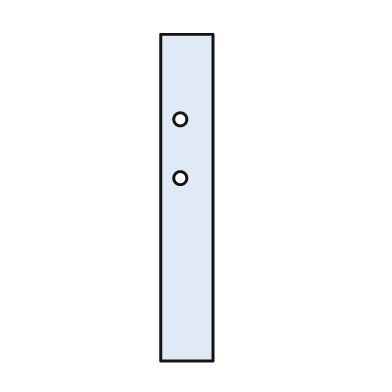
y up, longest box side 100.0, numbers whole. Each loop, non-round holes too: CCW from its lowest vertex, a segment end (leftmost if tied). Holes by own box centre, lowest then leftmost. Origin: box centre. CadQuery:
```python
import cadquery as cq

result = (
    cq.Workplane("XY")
    .moveTo(-8.0, -50.0)
    .lineTo(8.0, -50.0)
    .lineTo(8.0, 50.0)
    .lineTo(-8.0, 50.0)
    .close()
    .moveTo(-2.0, 6.0)
    .circle(2.0)
    .moveTo(-2.0, 24.0)
    .circle(2.0)
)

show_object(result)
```